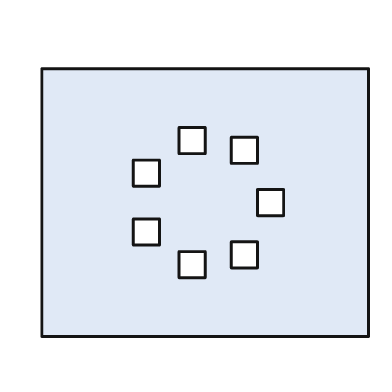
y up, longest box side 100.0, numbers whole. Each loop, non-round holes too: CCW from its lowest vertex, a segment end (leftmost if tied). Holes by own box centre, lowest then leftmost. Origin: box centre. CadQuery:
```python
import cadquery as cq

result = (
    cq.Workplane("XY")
    .moveTo(-50.0, -41.0)
    .lineTo(50.0, -41.0)
    .lineTo(50.0, 41.0)
    .lineTo(-50.0, 41.0)
    .close()
    .moveTo(-8.0, -23.0)
    .lineTo(0.0, -23.0)
    .lineTo(0.0, -15.0)
    .lineTo(-8.0, -15.0)
    .close()
    .moveTo(8.0, -20.0)
    .lineTo(16.0, -20.0)
    .lineTo(16.0, -12.0)
    .lineTo(8.0, -12.0)
    .close()
    .moveTo(-22.0, -13.0)
    .lineTo(-14.0, -13.0)
    .lineTo(-14.0, -5.0)
    .lineTo(-22.0, -5.0)
    .close()
    .moveTo(16.0, -4.0)
    .lineTo(24.0, -4.0)
    .lineTo(24.0, 4.0)
    .lineTo(16.0, 4.0)
    .close()
    .moveTo(-22.0, 5.0)
    .lineTo(-14.0, 5.0)
    .lineTo(-14.0, 13.0)
    .lineTo(-22.0, 13.0)
    .close()
    .moveTo(8.0, 12.0)
    .lineTo(16.0, 12.0)
    .lineTo(16.0, 20.0)
    .lineTo(8.0, 20.0)
    .close()
    .moveTo(-8.0, 15.0)
    .lineTo(0.0, 15.0)
    .lineTo(0.0, 23.0)
    .lineTo(-8.0, 23.0)
    .close()
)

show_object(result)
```